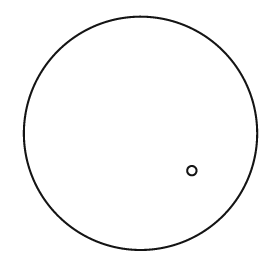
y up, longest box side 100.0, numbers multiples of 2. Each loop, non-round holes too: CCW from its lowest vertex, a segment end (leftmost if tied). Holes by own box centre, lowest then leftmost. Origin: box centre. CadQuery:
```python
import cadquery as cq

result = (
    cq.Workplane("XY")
    .moveTo(0.0, 0.0)
    .circle(50.0)
    .moveTo(22.0, -16.0)
    .circle(2.0)
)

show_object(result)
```